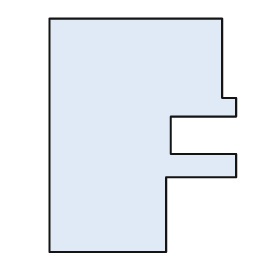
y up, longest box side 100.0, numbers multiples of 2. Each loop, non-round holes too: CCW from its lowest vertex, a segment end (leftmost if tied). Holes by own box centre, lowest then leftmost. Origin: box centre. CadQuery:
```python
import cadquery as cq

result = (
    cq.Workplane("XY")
    .moveTo(-40.0, -50.0)
    .lineTo(10.0, -50.0)
    .lineTo(10.0, -18.0)
    .lineTo(40.0, -18.0)
    .lineTo(40.0, -8.0)
    .lineTo(12.0, -8.0)
    .lineTo(12.0, 8.0)
    .lineTo(40.0, 8.0)
    .lineTo(40.0, 16.0)
    .lineTo(34.0, 16.0)
    .lineTo(34.0, 50.0)
    .lineTo(-40.0, 50.0)
    .close()
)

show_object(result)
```